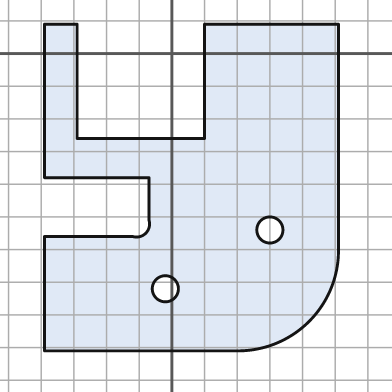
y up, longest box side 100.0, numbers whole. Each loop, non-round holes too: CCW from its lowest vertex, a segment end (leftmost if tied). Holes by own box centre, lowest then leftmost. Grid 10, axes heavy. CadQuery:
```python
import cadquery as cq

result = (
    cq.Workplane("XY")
    .moveTo(-39.0, -91.0)
    .lineTo(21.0, -91.0)
    .threePointArc((42.0, -82.0), (51.0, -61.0))
    .lineTo(51.0, 9.0)
    .lineTo(10.0, 9.0)
    .lineTo(10.0, -26.0)
    .lineTo(-29.0, -26.0)
    .lineTo(-29.0, 9.0)
    .lineTo(-39.0, 9.0)
    .lineTo(-39.0, -38.0)
    .lineTo(-7.0, -38.0)
    .lineTo(-7.0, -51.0)
    .threePointArc((-8.0, -55.0), (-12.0, -56.0))
    .lineTo(-39.0, -56.0)
    .close()
    .moveTo(-2.0, -72.0)
    .circle(4.0)
    .moveTo(30.0, -54.0)
    .circle(4.0)
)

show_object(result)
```